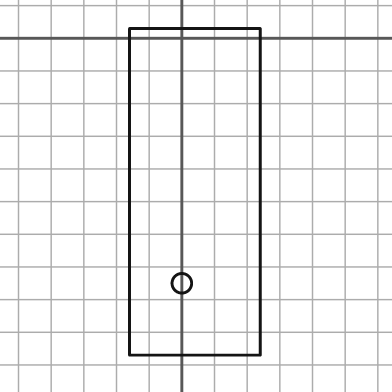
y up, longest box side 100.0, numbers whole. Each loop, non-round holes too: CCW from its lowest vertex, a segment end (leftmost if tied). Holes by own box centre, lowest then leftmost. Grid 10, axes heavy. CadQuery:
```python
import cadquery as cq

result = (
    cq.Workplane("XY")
    .moveTo(-16.0, -97.0)
    .lineTo(24.0, -97.0)
    .lineTo(24.0, 3.0)
    .lineTo(-16.0, 3.0)
    .close()
    .moveTo(0.0, -75.0)
    .circle(3.0)
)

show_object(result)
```